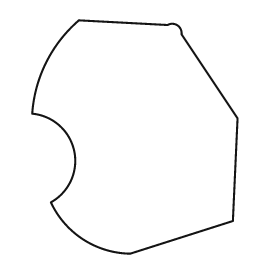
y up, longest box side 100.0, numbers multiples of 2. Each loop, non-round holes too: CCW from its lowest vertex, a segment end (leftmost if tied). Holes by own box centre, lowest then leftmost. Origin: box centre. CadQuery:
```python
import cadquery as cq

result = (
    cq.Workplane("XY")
    .moveTo(-2.0, -50.0)
    .lineTo(42.0, -36.0)
    .lineTo(44.0, 8.0)
    .lineTo(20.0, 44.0)
    .threePointArc((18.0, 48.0), (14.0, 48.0))
    .lineTo(-24.0, 50.0)
    .threePointArc((-38.0, 32.0), (-44.0, 10.0))
    .threePointArc((-26.0, -6.0), (-36.0, -28.0))
    .threePointArc((-22.0, -44.0), (-2.0, -50.0))
    .close()
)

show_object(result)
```